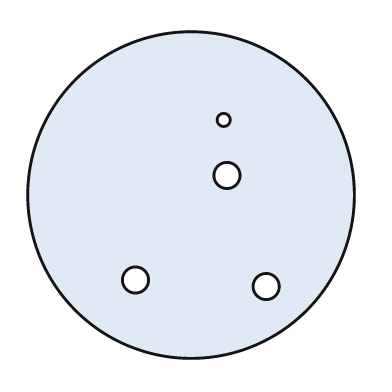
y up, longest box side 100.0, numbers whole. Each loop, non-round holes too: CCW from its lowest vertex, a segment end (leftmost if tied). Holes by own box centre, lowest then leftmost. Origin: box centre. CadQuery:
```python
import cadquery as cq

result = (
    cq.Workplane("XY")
    .moveTo(0.0, 0.0)
    .circle(50.0)
    .moveTo(23.0, -28.0)
    .circle(4.0)
    .moveTo(-17.0, -26.0)
    .circle(4.0)
    .moveTo(11.0, 6.0)
    .circle(4.0)
    .moveTo(10.0, 23.0)
    .circle(2.0)
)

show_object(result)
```